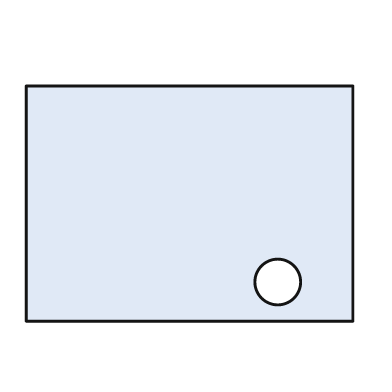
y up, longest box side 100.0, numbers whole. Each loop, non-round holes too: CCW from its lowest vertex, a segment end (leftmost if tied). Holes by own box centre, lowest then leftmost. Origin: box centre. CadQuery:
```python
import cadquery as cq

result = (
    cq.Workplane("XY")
    .moveTo(-50.0, -36.0)
    .lineTo(50.0, -36.0)
    .lineTo(50.0, 36.0)
    .lineTo(-50.0, 36.0)
    .close()
    .moveTo(27.0, -24.0)
    .circle(7.0)
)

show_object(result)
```